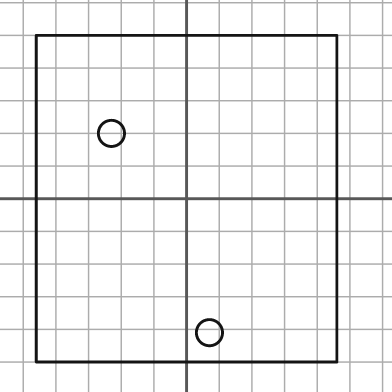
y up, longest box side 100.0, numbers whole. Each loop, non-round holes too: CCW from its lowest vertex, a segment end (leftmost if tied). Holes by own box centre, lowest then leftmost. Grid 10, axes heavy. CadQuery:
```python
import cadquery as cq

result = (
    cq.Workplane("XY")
    .moveTo(-46.0, -50.0)
    .lineTo(46.0, -50.0)
    .lineTo(46.0, 50.0)
    .lineTo(-46.0, 50.0)
    .close()
    .moveTo(7.0, -41.0)
    .circle(4.0)
    .moveTo(-23.0, 20.0)
    .circle(4.0)
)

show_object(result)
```